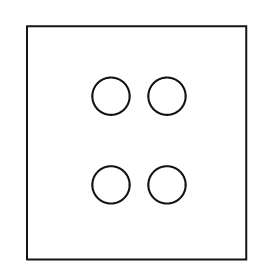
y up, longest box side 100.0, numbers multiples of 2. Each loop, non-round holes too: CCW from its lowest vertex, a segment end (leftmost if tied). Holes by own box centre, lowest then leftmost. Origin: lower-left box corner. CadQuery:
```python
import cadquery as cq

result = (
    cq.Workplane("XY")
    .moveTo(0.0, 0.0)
    .lineTo(94.0, 0.0)
    .lineTo(94.0, 100.0)
    .lineTo(0.0, 100.0)
    .close()
    .moveTo(36.0, 32.0)
    .circle(8.0)
    .moveTo(60.0, 32.0)
    .circle(8.0)
    .moveTo(36.0, 70.0)
    .circle(8.0)
    .moveTo(60.0, 70.0)
    .circle(8.0)
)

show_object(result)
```